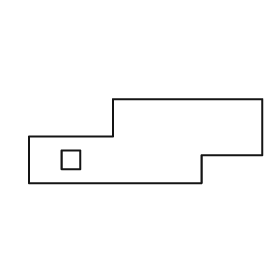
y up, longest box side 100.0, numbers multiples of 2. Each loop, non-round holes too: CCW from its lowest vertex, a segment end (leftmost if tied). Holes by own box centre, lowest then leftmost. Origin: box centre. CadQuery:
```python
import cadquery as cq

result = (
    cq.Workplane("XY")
    .moveTo(-50.0, -18.0)
    .lineTo(24.0, -18.0)
    .lineTo(24.0, -6.0)
    .lineTo(50.0, -6.0)
    .lineTo(50.0, 18.0)
    .lineTo(-14.0, 18.0)
    .lineTo(-14.0, 2.0)
    .lineTo(-50.0, 2.0)
    .close()
    .moveTo(-36.0, -12.0)
    .lineTo(-28.0, -12.0)
    .lineTo(-28.0, -4.0)
    .lineTo(-36.0, -4.0)
    .close()
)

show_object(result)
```